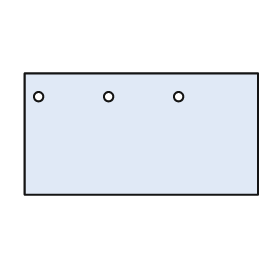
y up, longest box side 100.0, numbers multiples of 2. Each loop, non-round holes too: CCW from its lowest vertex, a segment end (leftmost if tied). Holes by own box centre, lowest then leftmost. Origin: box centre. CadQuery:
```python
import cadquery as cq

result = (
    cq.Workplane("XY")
    .moveTo(-50.0, -26.0)
    .lineTo(50.0, -26.0)
    .lineTo(50.0, 26.0)
    .lineTo(-50.0, 26.0)
    .close()
    .moveTo(-44.0, 16.0)
    .circle(2.0)
    .moveTo(-14.0, 16.0)
    .circle(2.0)
    .moveTo(16.0, 16.0)
    .circle(2.0)
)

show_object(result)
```